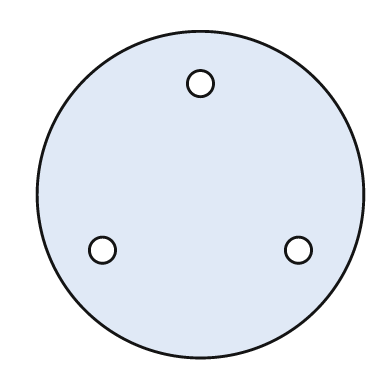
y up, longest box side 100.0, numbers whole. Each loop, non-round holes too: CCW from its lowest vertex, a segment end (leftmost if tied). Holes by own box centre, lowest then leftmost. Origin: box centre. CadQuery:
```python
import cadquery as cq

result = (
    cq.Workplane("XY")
    .moveTo(0.0, 0.0)
    .circle(50.0)
    .moveTo(-30.0, -17.0)
    .circle(4.0)
    .moveTo(30.0, -17.0)
    .circle(4.0)
    .moveTo(0.0, 34.0)
    .circle(4.0)
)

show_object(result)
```